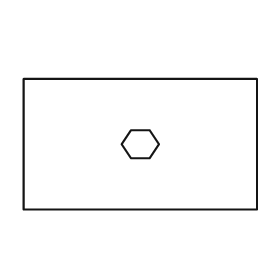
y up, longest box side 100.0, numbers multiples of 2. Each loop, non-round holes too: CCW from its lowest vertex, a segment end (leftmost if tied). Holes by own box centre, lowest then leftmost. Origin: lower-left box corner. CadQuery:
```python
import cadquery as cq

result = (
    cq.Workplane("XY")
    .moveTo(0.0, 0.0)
    .lineTo(100.0, 0.0)
    .lineTo(100.0, 56.0)
    .lineTo(0.0, 56.0)
    .close()
    .moveTo(46.0, 22.0)
    .lineTo(54.0, 22.0)
    .lineTo(58.0, 28.0)
    .lineTo(54.0, 34.0)
    .lineTo(46.0, 34.0)
    .lineTo(42.0, 28.0)
    .close()
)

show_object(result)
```